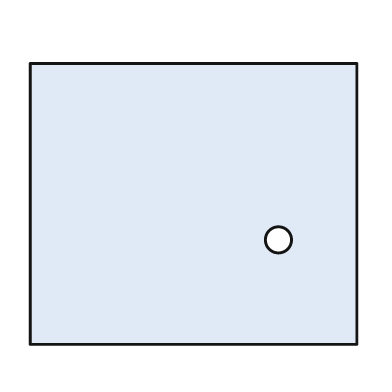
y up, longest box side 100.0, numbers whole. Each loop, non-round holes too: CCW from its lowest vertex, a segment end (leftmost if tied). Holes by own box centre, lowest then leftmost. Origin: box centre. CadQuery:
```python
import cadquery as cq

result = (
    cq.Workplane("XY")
    .moveTo(-50.0, -43.0)
    .lineTo(50.0, -43.0)
    .lineTo(50.0, 43.0)
    .lineTo(-50.0, 43.0)
    .close()
    .moveTo(26.0, -11.0)
    .circle(4.0)
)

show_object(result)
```